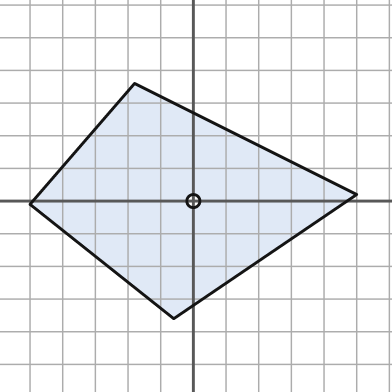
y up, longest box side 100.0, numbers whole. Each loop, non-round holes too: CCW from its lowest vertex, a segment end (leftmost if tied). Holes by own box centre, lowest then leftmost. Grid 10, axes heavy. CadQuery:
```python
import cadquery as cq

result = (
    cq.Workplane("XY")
    .moveTo(-6.0, -36.0)
    .lineTo(50.0, 2.0)
    .lineTo(-18.0, 36.0)
    .lineTo(-50.0, -1.0)
    .close()
    .moveTo(0.0, 0.0)
    .circle(2.0)
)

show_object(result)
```